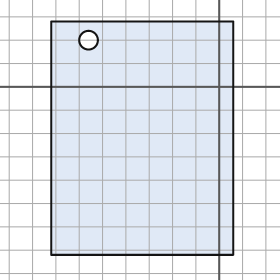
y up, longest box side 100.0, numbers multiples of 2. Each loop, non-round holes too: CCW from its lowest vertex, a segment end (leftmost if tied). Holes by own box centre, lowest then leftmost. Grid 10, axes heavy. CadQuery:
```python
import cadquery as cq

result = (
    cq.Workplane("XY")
    .moveTo(-72.0, -72.0)
    .lineTo(6.0, -72.0)
    .lineTo(6.0, 28.0)
    .lineTo(-72.0, 28.0)
    .close()
    .moveTo(-56.0, 20.0)
    .circle(4.0)
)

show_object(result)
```